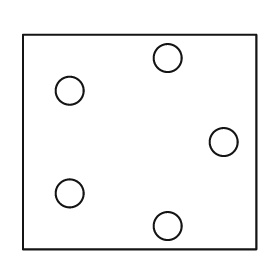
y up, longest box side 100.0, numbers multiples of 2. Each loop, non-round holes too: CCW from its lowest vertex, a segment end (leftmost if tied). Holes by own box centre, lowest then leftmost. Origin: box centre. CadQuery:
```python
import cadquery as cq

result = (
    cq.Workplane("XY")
    .moveTo(-50.0, -46.0)
    .lineTo(50.0, -46.0)
    .lineTo(50.0, 46.0)
    .lineTo(-50.0, 46.0)
    .close()
    .moveTo(12.0, -36.0)
    .circle(6.0)
    .moveTo(-30.0, -22.0)
    .circle(6.0)
    .moveTo(36.0, 0.0)
    .circle(6.0)
    .moveTo(-30.0, 22.0)
    .circle(6.0)
    .moveTo(12.0, 36.0)
    .circle(6.0)
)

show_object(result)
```